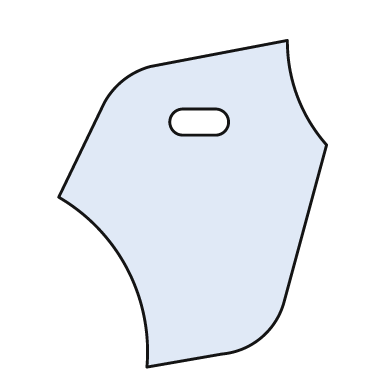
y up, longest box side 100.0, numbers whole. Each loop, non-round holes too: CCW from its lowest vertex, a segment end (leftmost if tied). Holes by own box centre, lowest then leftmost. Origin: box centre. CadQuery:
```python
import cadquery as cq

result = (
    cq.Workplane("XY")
    .moveTo(-14.0, -50.0)
    .lineTo(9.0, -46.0)
    .threePointArc((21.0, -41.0), (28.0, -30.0))
    .lineTo(41.0, 18.0)
    .threePointArc((32.0, 33.0), (29.0, 50.0))
    .lineTo(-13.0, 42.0)
    .threePointArc((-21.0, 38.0), (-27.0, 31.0))
    .lineTo(-41.0, 2.0)
    .threePointArc((-20.0, -20.0), (-14.0, -50.0))
    .close()
    .moveTo(-3.0, 21.0)
    .lineTo(7.0, 21.0)
    .threePointArc((11.0, 25.0), (7.0, 29.0))
    .lineTo(-3.0, 29.0)
    .threePointArc((-7.0, 25.0), (-3.0, 21.0))
    .close()
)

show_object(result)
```